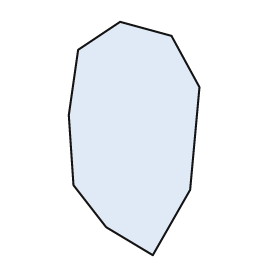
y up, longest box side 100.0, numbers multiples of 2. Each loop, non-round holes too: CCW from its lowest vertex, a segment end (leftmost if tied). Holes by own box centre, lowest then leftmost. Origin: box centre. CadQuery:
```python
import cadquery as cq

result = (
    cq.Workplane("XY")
    .moveTo(8.0, -50.0)
    .lineTo(24.0, -22.0)
    .lineTo(28.0, 22.0)
    .lineTo(16.0, 44.0)
    .lineTo(-6.0, 50.0)
    .lineTo(-24.0, 38.0)
    .lineTo(-28.0, 10.0)
    .lineTo(-26.0, -20.0)
    .lineTo(-12.0, -38.0)
    .close()
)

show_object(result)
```